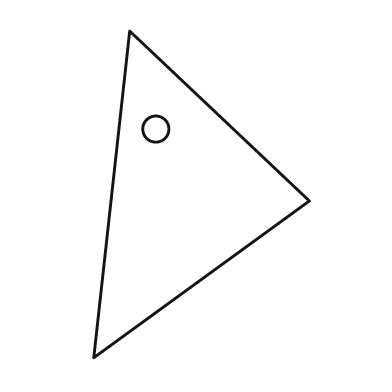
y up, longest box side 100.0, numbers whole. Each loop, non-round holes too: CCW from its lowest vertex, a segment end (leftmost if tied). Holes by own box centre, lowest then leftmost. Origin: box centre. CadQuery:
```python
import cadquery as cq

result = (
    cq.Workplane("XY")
    .moveTo(-33.0, -50.0)
    .lineTo(33.0, -2.0)
    .lineTo(-22.0, 50.0)
    .close()
    .moveTo(-14.0, 20.0)
    .circle(4.0)
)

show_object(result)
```